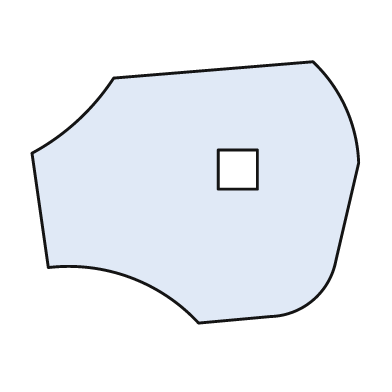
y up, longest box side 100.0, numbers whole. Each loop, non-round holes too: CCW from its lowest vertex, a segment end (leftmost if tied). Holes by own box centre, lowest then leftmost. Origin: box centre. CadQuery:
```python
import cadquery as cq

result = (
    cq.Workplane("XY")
    .moveTo(1.0, -40.0)
    .lineTo(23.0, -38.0)
    .threePointArc((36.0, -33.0), (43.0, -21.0))
    .lineTo(50.0, 9.0)
    .threePointArc((46.0, 26.0), (36.0, 40.0))
    .lineTo(-25.0, 35.0)
    .threePointArc((-36.0, 22.0), (-50.0, 12.0))
    .lineTo(-45.0, -23.0)
    .threePointArc((-20.0, -26.0), (1.0, -40.0))
    .close()
    .moveTo(7.0, 1.0)
    .lineTo(19.0, 1.0)
    .lineTo(19.0, 13.0)
    .lineTo(7.0, 13.0)
    .close()
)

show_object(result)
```